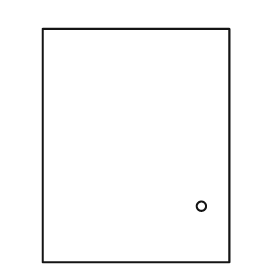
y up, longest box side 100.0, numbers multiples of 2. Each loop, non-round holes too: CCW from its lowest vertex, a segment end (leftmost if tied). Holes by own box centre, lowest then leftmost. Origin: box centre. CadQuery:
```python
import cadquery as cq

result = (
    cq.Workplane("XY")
    .moveTo(-40.0, -50.0)
    .lineTo(40.0, -50.0)
    .lineTo(40.0, 50.0)
    .lineTo(-40.0, 50.0)
    .close()
    .moveTo(28.0, -26.0)
    .circle(2.0)
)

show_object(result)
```